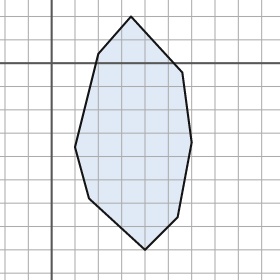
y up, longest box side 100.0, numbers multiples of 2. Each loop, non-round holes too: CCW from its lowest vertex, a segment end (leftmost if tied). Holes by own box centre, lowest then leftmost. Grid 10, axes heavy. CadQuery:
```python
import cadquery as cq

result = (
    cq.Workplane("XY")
    .moveTo(40.0, -80.0)
    .lineTo(54.0, -66.0)
    .lineTo(60.0, -34.0)
    .lineTo(56.0, -4.0)
    .lineTo(34.0, 20.0)
    .lineTo(20.0, 4.0)
    .lineTo(10.0, -36.0)
    .lineTo(16.0, -58.0)
    .close()
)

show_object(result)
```